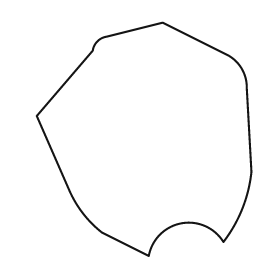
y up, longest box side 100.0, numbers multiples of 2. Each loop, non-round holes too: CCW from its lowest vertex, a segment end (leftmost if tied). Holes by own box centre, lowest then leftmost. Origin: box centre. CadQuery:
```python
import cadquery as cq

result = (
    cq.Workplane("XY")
    .moveTo(2.0, -50.0)
    .threePointArc((16.0, -36.0), (34.0, -44.0))
    .threePointArc((42.0, -30.0), (46.0, -14.0))
    .lineTo(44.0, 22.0)
    .threePointArc((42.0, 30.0), (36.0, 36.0))
    .lineTo(8.0, 50.0)
    .lineTo(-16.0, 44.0)
    .threePointArc((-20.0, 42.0), (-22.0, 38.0))
    .lineTo(-46.0, 10.0)
    .lineTo(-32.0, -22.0)
    .threePointArc((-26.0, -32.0), (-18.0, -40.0))
    .close()
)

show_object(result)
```